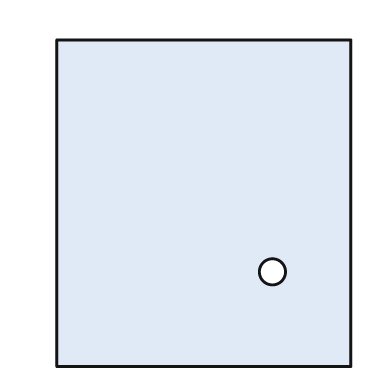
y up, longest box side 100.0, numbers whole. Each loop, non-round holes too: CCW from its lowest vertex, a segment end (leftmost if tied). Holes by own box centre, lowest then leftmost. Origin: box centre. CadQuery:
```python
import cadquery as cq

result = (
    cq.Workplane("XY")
    .moveTo(-45.0, -50.0)
    .lineTo(45.0, -50.0)
    .lineTo(45.0, 50.0)
    .lineTo(-45.0, 50.0)
    .close()
    .moveTo(21.0, -21.0)
    .circle(4.0)
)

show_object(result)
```